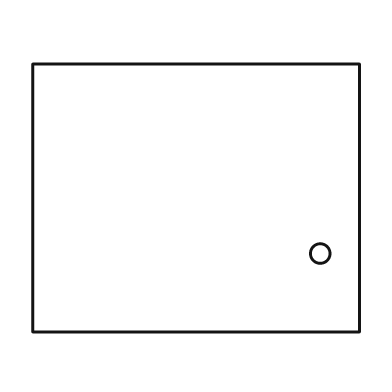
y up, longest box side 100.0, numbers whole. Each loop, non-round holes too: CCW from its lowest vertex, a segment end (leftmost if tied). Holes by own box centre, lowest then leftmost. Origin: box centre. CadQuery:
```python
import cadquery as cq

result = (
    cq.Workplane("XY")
    .moveTo(-50.0, -41.0)
    .lineTo(50.0, -41.0)
    .lineTo(50.0, 41.0)
    .lineTo(-50.0, 41.0)
    .close()
    .moveTo(38.0, -17.0)
    .circle(3.0)
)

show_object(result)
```